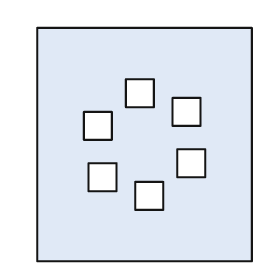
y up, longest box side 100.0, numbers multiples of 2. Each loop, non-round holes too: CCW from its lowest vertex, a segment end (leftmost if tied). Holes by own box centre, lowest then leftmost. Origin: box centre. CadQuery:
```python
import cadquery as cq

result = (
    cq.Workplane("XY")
    .moveTo(-46.0, -50.0)
    .lineTo(46.0, -50.0)
    .lineTo(46.0, 50.0)
    .lineTo(-46.0, 50.0)
    .close()
    .moveTo(-4.0, -28.0)
    .lineTo(8.0, -28.0)
    .lineTo(8.0, -16.0)
    .lineTo(-4.0, -16.0)
    .close()
    .moveTo(-24.0, -20.0)
    .lineTo(-12.0, -20.0)
    .lineTo(-12.0, -8.0)
    .lineTo(-24.0, -8.0)
    .close()
    .moveTo(14.0, -14.0)
    .lineTo(26.0, -14.0)
    .lineTo(26.0, -2.0)
    .lineTo(14.0, -2.0)
    .close()
    .moveTo(-26.0, 2.0)
    .lineTo(-14.0, 2.0)
    .lineTo(-14.0, 14.0)
    .lineTo(-26.0, 14.0)
    .close()
    .moveTo(12.0, 8.0)
    .lineTo(24.0, 8.0)
    .lineTo(24.0, 20.0)
    .lineTo(12.0, 20.0)
    .close()
    .moveTo(-8.0, 16.0)
    .lineTo(4.0, 16.0)
    .lineTo(4.0, 28.0)
    .lineTo(-8.0, 28.0)
    .close()
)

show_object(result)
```